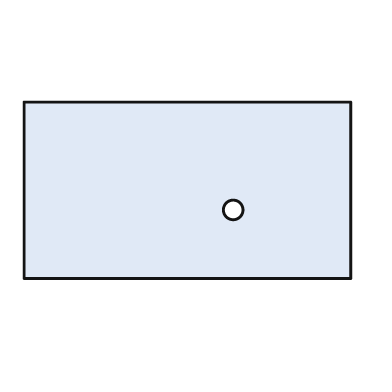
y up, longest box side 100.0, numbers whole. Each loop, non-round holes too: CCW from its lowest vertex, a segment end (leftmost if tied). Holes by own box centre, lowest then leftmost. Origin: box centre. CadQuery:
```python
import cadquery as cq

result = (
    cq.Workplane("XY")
    .moveTo(-50.0, -27.0)
    .lineTo(50.0, -27.0)
    .lineTo(50.0, 27.0)
    .lineTo(-50.0, 27.0)
    .close()
    .moveTo(14.0, -6.0)
    .circle(3.0)
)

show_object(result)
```